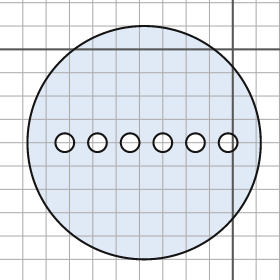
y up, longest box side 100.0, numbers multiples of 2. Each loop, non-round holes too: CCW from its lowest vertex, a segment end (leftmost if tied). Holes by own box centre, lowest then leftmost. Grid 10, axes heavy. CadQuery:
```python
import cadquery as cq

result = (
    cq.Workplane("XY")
    .moveTo(-38.0, -40.0)
    .circle(50.0)
    .moveTo(-72.0, -40.0)
    .circle(4.0)
    .moveTo(-58.0, -40.0)
    .circle(4.0)
    .moveTo(-44.0, -40.0)
    .circle(4.0)
    .moveTo(-30.0, -40.0)
    .circle(4.0)
    .moveTo(-16.0, -40.0)
    .circle(4.0)
    .moveTo(-2.0, -40.0)
    .circle(4.0)
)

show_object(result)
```